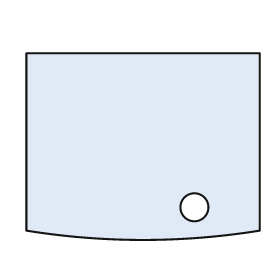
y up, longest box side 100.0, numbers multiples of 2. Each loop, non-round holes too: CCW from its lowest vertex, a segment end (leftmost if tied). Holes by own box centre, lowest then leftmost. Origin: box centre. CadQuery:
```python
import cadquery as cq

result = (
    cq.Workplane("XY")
    .moveTo(-50.0, -36.0)
    .threePointArc((0.0, -40.0), (50.0, -36.0))
    .lineTo(50.0, 40.0)
    .lineTo(-50.0, 40.0)
    .close()
    .moveTo(22.0, -26.0)
    .circle(6.0)
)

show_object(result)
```